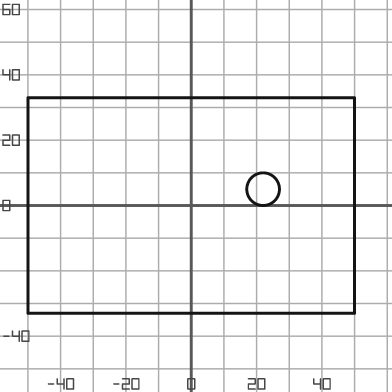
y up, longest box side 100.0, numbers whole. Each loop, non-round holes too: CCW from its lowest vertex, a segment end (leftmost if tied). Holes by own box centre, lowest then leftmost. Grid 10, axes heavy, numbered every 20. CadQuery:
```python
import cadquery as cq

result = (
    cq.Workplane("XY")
    .moveTo(-50.0, -33.0)
    .lineTo(50.0, -33.0)
    .lineTo(50.0, 33.0)
    .lineTo(-50.0, 33.0)
    .close()
    .moveTo(22.0, 5.0)
    .circle(5.0)
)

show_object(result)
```